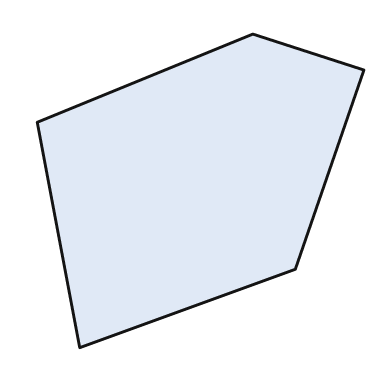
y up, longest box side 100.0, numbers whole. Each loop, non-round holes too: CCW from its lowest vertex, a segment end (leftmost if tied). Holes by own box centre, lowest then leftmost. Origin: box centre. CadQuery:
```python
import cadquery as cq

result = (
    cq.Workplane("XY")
    .moveTo(-37.0, -48.0)
    .lineTo(29.0, -24.0)
    .lineTo(50.0, 37.0)
    .lineTo(16.0, 48.0)
    .lineTo(-50.0, 21.0)
    .close()
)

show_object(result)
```